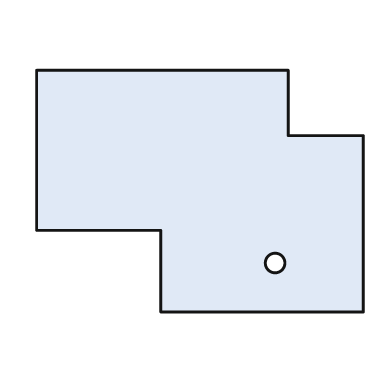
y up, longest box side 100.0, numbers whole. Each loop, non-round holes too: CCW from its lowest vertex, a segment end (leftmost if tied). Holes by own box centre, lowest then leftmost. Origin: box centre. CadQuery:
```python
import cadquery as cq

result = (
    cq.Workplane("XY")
    .moveTo(-12.0, -37.0)
    .lineTo(50.0, -37.0)
    .lineTo(50.0, 17.0)
    .lineTo(27.0, 17.0)
    .lineTo(27.0, 37.0)
    .lineTo(-50.0, 37.0)
    .lineTo(-50.0, -12.0)
    .lineTo(-12.0, -12.0)
    .close()
    .moveTo(23.0, -22.0)
    .circle(3.0)
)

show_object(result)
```